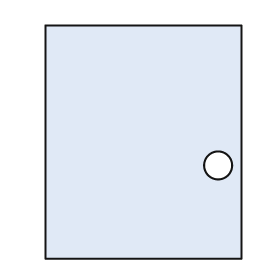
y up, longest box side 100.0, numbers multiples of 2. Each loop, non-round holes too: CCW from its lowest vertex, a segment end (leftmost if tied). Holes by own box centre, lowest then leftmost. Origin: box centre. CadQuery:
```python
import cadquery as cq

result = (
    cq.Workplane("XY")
    .moveTo(-42.0, -50.0)
    .lineTo(42.0, -50.0)
    .lineTo(42.0, 50.0)
    .lineTo(-42.0, 50.0)
    .close()
    .moveTo(32.0, -10.0)
    .circle(6.0)
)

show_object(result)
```